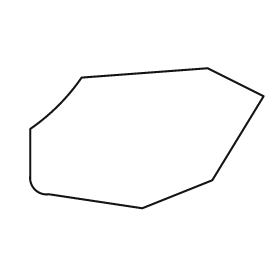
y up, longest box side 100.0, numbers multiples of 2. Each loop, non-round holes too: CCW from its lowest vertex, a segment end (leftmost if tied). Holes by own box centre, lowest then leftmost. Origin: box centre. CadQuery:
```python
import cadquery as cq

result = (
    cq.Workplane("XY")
    .moveTo(-2.0, -30.0)
    .lineTo(28.0, -18.0)
    .lineTo(50.0, 18.0)
    .lineTo(26.0, 30.0)
    .lineTo(-28.0, 26.0)
    .threePointArc((-38.0, 14.0), (-50.0, 4.0))
    .lineTo(-50.0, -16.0)
    .threePointArc((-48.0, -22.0), (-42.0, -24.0))
    .close()
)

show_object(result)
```